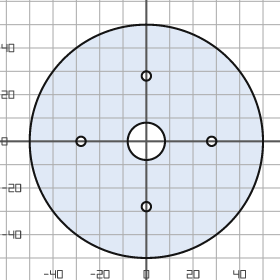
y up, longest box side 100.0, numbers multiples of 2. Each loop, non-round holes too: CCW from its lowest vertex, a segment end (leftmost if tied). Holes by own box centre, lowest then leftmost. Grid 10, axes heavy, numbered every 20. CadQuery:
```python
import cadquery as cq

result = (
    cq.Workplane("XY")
    .moveTo(0.0, 0.0)
    .circle(50.0)
    .moveTo(0.0, -28.0)
    .circle(2.0)
    .moveTo(-28.0, 0.0)
    .circle(2.0)
    .moveTo(0.0, 0.0)
    .circle(8.0)
    .moveTo(28.0, 0.0)
    .circle(2.0)
    .moveTo(0.0, 28.0)
    .circle(2.0)
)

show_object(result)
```